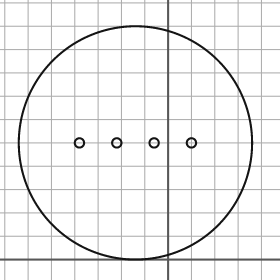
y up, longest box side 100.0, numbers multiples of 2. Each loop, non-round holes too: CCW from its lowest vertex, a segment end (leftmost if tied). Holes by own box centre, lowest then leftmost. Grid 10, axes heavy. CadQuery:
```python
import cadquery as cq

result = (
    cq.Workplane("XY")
    .moveTo(-14.0, 50.0)
    .circle(50.0)
    .moveTo(-38.0, 50.0)
    .circle(2.0)
    .moveTo(-22.0, 50.0)
    .circle(2.0)
    .moveTo(-6.0, 50.0)
    .circle(2.0)
    .moveTo(10.0, 50.0)
    .circle(2.0)
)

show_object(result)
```